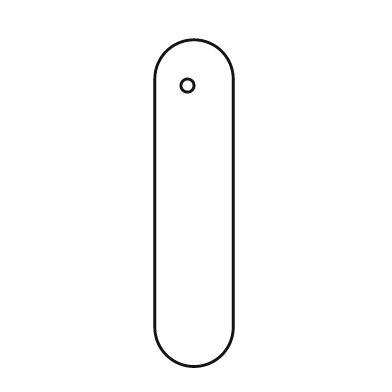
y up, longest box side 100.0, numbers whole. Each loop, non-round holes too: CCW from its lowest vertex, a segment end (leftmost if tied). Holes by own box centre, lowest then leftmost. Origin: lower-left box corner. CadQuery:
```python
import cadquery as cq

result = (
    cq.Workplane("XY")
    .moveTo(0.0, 12.0)
    .threePointArc((12.0, 0.0), (24.0, 12.0))
    .lineTo(24.0, 88.0)
    .threePointArc((12.0, 100.0), (0.0, 88.0))
    .close()
    .moveTo(10.0, 86.0)
    .circle(2.0)
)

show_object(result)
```